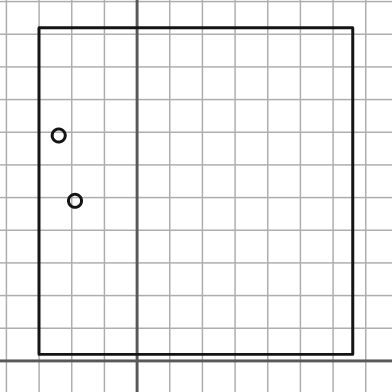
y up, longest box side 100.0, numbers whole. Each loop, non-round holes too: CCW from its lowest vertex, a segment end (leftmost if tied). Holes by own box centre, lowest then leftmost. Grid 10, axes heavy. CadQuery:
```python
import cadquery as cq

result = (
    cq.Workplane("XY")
    .moveTo(-30.0, 2.0)
    .lineTo(66.0, 2.0)
    .lineTo(66.0, 102.0)
    .lineTo(-30.0, 102.0)
    .close()
    .moveTo(-19.0, 49.0)
    .circle(2.0)
    .moveTo(-24.0, 69.0)
    .circle(2.0)
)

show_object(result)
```